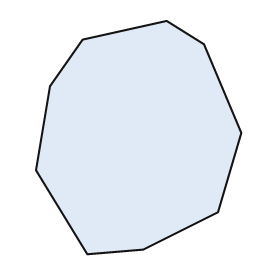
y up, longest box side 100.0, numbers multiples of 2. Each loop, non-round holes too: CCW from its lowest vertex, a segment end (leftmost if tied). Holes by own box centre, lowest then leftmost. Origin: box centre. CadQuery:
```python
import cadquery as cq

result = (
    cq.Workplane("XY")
    .moveTo(-22.0, -50.0)
    .lineTo(2.0, -48.0)
    .lineTo(34.0, -32.0)
    .lineTo(44.0, 2.0)
    .lineTo(28.0, 40.0)
    .lineTo(12.0, 50.0)
    .lineTo(-24.0, 42.0)
    .lineTo(-38.0, 22.0)
    .lineTo(-44.0, -14.0)
    .close()
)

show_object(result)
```